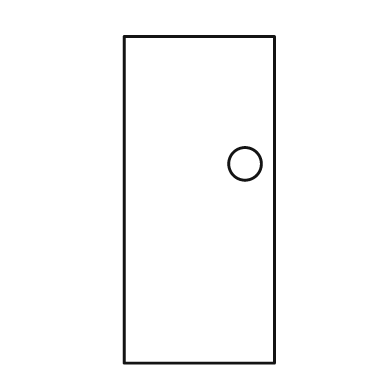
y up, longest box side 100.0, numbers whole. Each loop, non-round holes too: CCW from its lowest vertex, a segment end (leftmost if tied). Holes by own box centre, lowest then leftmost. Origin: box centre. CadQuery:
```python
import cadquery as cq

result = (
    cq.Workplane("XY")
    .moveTo(-23.0, -50.0)
    .lineTo(23.0, -50.0)
    .lineTo(23.0, 50.0)
    .lineTo(-23.0, 50.0)
    .close()
    .moveTo(14.0, 11.0)
    .circle(5.0)
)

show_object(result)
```